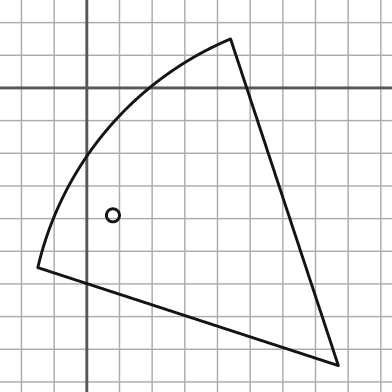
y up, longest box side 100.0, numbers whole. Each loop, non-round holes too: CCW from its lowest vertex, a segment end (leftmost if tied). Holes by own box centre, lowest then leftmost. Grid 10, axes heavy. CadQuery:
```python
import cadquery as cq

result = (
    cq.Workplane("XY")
    .moveTo(77.0, -85.0)
    .lineTo(44.0, 15.0)
    .threePointArc((6.0, -13.0), (-15.0, -55.0))
    .close()
    .moveTo(8.0, -39.0)
    .circle(2.0)
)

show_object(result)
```